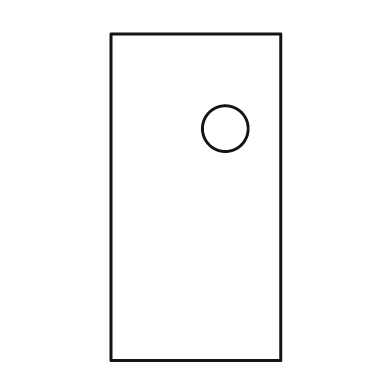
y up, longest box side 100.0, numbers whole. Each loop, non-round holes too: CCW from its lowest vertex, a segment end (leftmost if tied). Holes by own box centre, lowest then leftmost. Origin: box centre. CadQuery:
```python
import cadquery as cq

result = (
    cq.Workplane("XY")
    .moveTo(-26.0, -50.0)
    .lineTo(26.0, -50.0)
    .lineTo(26.0, 50.0)
    .lineTo(-26.0, 50.0)
    .close()
    .moveTo(9.0, 21.0)
    .circle(7.0)
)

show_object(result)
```